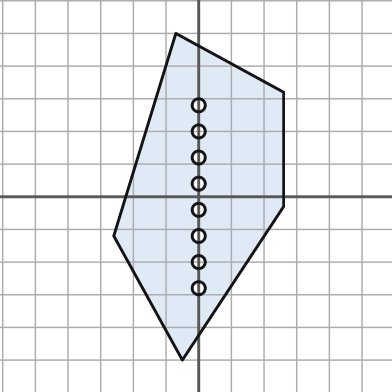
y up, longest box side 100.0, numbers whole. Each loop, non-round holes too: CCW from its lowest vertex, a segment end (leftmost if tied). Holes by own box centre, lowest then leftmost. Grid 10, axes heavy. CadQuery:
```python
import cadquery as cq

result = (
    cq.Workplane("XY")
    .moveTo(-5.0, -50.0)
    .lineTo(26.0, -3.0)
    .lineTo(26.0, 32.0)
    .lineTo(-7.0, 50.0)
    .lineTo(-26.0, -12.0)
    .close()
    .moveTo(0.0, -28.0)
    .circle(2.0)
    .moveTo(0.0, -20.0)
    .circle(2.0)
    .moveTo(0.0, -12.0)
    .circle(2.0)
    .moveTo(0.0, -4.0)
    .circle(2.0)
    .moveTo(0.0, 4.0)
    .circle(2.0)
    .moveTo(0.0, 12.0)
    .circle(2.0)
    .moveTo(0.0, 20.0)
    .circle(2.0)
    .moveTo(0.0, 28.0)
    .circle(2.0)
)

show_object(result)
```